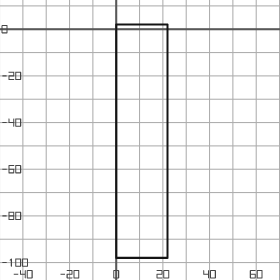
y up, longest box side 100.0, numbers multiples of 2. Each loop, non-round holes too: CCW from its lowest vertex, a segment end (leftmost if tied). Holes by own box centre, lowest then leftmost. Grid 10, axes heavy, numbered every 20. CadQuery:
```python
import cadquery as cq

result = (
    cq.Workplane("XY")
    .moveTo(0.0, -98.0)
    .lineTo(22.0, -98.0)
    .lineTo(22.0, 2.0)
    .lineTo(0.0, 2.0)
    .close()
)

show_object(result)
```